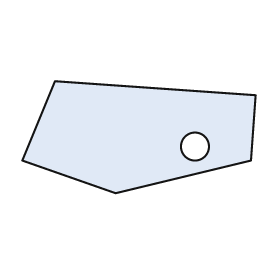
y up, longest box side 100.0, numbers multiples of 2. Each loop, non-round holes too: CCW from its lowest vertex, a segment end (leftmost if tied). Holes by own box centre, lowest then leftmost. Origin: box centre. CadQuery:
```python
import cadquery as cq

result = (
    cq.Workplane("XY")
    .moveTo(-10.0, -24.0)
    .lineTo(48.0, -10.0)
    .lineTo(50.0, 18.0)
    .lineTo(-36.0, 24.0)
    .lineTo(-50.0, -10.0)
    .close()
    .moveTo(24.0, -4.0)
    .circle(6.0)
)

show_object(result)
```